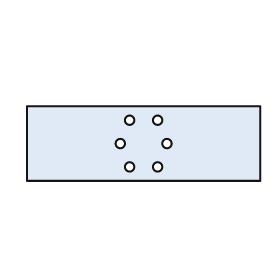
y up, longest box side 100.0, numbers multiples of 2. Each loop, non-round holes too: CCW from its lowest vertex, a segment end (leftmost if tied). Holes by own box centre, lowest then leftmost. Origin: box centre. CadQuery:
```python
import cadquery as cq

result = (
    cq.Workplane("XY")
    .moveTo(-50.0, -16.0)
    .lineTo(50.0, -16.0)
    .lineTo(50.0, 16.0)
    .lineTo(-50.0, 16.0)
    .close()
    .moveTo(-6.0, -10.0)
    .circle(2.0)
    .moveTo(6.0, -10.0)
    .circle(2.0)
    .moveTo(-10.0, 0.0)
    .circle(2.0)
    .moveTo(10.0, 0.0)
    .circle(2.0)
    .moveTo(-6.0, 10.0)
    .circle(2.0)
    .moveTo(6.0, 10.0)
    .circle(2.0)
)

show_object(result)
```